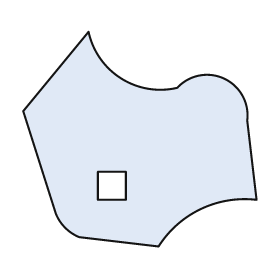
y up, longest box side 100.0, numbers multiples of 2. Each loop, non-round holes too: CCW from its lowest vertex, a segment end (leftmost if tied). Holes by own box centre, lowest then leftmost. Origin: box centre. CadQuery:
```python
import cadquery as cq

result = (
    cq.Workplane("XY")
    .moveTo(8.0, -46.0)
    .threePointArc((26.0, -30.0), (50.0, -26.0))
    .lineTo(46.0, 8.0)
    .threePointArc((36.0, 26.0), (16.0, 22.0))
    .threePointArc((-8.0, 26.0), (-22.0, 46.0))
    .lineTo(-50.0, 12.0)
    .lineTo(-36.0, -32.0)
    .threePointArc((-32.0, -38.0), (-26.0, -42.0))
    .close()
    .moveTo(-18.0, -26.0)
    .lineTo(-6.0, -26.0)
    .lineTo(-6.0, -14.0)
    .lineTo(-18.0, -14.0)
    .close()
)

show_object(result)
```